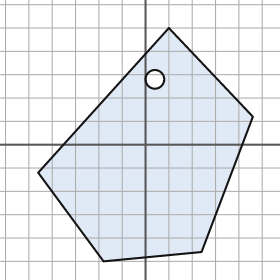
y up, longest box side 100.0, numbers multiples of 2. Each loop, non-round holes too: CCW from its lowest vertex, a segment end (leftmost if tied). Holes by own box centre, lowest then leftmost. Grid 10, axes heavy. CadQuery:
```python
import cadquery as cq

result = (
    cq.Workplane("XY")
    .moveTo(-18.0, -50.0)
    .lineTo(24.0, -46.0)
    .lineTo(46.0, 12.0)
    .lineTo(10.0, 50.0)
    .lineTo(-46.0, -12.0)
    .close()
    .moveTo(4.0, 28.0)
    .circle(4.0)
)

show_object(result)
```